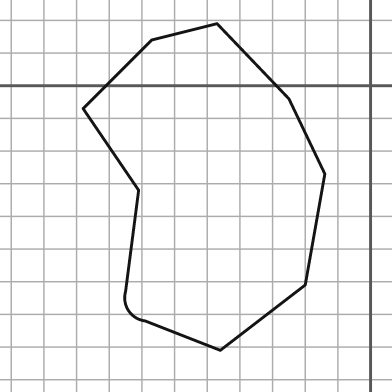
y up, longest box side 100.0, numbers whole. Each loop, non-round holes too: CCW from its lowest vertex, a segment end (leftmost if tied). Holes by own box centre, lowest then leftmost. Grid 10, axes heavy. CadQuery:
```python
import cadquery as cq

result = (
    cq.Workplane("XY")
    .moveTo(-46.0, -81.0)
    .lineTo(-20.0, -61.0)
    .lineTo(-14.0, -27.0)
    .lineTo(-25.0, -4.0)
    .lineTo(-47.0, 19.0)
    .lineTo(-67.0, 14.0)
    .lineTo(-88.0, -7.0)
    .lineTo(-71.0, -32.0)
    .lineTo(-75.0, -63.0)
    .threePointArc((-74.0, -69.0), (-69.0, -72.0))
    .close()
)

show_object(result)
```